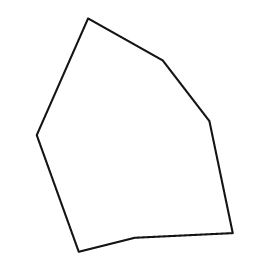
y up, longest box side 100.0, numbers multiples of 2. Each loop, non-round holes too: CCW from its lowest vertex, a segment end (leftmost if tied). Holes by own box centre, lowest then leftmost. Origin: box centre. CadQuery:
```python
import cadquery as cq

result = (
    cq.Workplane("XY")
    .moveTo(-24.0, -50.0)
    .lineTo(0.0, -44.0)
    .lineTo(42.0, -42.0)
    .lineTo(32.0, 6.0)
    .lineTo(12.0, 32.0)
    .lineTo(-20.0, 50.0)
    .lineTo(-42.0, 0.0)
    .close()
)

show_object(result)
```